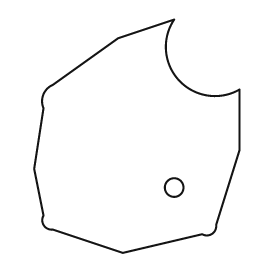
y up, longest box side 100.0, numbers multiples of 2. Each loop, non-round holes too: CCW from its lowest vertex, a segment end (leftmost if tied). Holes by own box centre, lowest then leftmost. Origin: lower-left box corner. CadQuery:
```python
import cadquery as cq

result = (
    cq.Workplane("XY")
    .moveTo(38.0, 0.0)
    .lineTo(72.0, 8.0)
    .threePointArc((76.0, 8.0), (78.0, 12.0))
    .lineTo(88.0, 44.0)
    .lineTo(88.0, 70.0)
    .threePointArc((62.0, 74.0), (60.0, 100.0))
    .lineTo(36.0, 92.0)
    .lineTo(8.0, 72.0)
    .threePointArc((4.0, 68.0), (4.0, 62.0))
    .lineTo(0.0, 36.0)
    .lineTo(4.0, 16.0)
    .threePointArc((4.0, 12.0), (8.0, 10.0))
    .close()
    .moveTo(60.0, 28.0)
    .circle(4.0)
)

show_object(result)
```